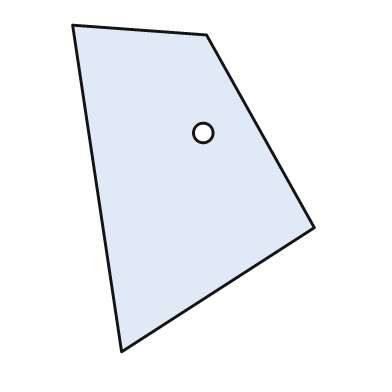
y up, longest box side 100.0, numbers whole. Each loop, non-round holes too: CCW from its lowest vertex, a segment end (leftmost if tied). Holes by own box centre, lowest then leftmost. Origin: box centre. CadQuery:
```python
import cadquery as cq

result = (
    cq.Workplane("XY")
    .moveTo(-22.0, -50.0)
    .lineTo(37.0, -12.0)
    .lineTo(4.0, 47.0)
    .lineTo(-37.0, 50.0)
    .close()
    .moveTo(3.0, 17.0)
    .circle(3.0)
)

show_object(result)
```